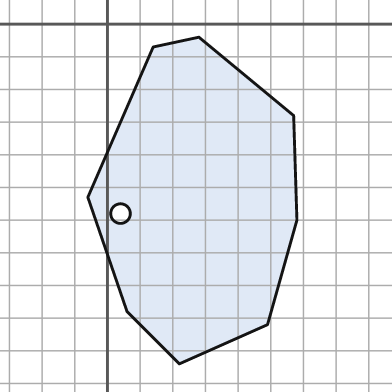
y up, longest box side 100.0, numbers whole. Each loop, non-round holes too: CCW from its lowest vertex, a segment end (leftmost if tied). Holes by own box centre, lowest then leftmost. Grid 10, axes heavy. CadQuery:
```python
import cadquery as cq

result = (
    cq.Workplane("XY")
    .moveTo(22.0, -104.0)
    .lineTo(49.0, -92.0)
    .lineTo(58.0, -60.0)
    .lineTo(57.0, -28.0)
    .lineTo(28.0, -4.0)
    .lineTo(14.0, -7.0)
    .lineTo(-6.0, -53.0)
    .lineTo(6.0, -88.0)
    .close()
    .moveTo(4.0, -58.0)
    .circle(3.0)
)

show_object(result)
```